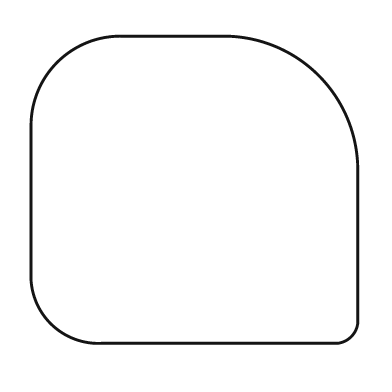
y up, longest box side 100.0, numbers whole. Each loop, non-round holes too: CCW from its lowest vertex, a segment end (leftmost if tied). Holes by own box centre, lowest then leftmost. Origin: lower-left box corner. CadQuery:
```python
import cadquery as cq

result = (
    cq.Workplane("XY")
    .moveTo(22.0, 0.0)
    .lineTo(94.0, 0.0)
    .threePointArc((98.0, 2.0), (100.0, 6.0))
    .lineTo(100.0, 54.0)
    .threePointArc((88.0, 82.0), (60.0, 94.0))
    .lineTo(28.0, 94.0)
    .threePointArc((8.0, 86.0), (0.0, 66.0))
    .lineTo(0.0, 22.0)
    .threePointArc((6.0, 6.0), (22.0, 0.0))
    .close()
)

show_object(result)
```